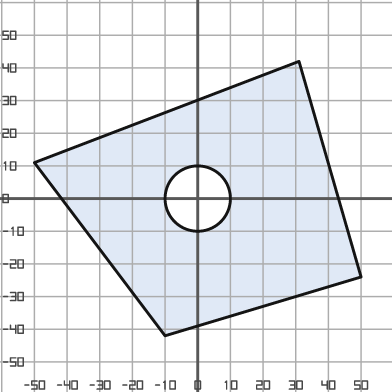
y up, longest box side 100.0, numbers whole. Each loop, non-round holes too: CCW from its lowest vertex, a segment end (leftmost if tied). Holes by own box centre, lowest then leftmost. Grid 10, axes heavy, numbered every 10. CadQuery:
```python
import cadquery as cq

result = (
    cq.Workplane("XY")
    .moveTo(-10.0, -42.0)
    .lineTo(50.0, -24.0)
    .lineTo(31.0, 42.0)
    .lineTo(-50.0, 11.0)
    .close()
    .moveTo(0.0, 0.0)
    .circle(10.0)
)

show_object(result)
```